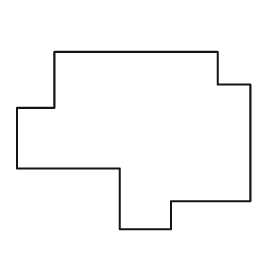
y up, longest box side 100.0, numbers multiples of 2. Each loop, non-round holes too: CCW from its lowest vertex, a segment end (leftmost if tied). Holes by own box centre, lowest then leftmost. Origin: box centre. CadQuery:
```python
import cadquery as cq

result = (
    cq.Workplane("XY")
    .moveTo(-6.0, -38.0)
    .lineTo(16.0, -38.0)
    .lineTo(16.0, -26.0)
    .lineTo(50.0, -26.0)
    .lineTo(50.0, 24.0)
    .lineTo(36.0, 24.0)
    .lineTo(36.0, 38.0)
    .lineTo(-34.0, 38.0)
    .lineTo(-34.0, 14.0)
    .lineTo(-50.0, 14.0)
    .lineTo(-50.0, -12.0)
    .lineTo(-6.0, -12.0)
    .close()
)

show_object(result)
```